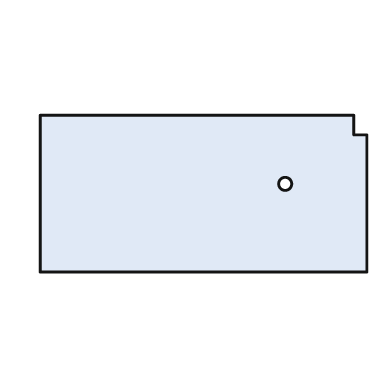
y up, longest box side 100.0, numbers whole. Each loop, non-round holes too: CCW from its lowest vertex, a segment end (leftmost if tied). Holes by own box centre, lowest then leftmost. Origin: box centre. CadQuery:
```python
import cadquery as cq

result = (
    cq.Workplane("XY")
    .moveTo(-50.0, -24.0)
    .lineTo(50.0, -24.0)
    .lineTo(50.0, 18.0)
    .lineTo(46.0, 18.0)
    .lineTo(46.0, 24.0)
    .lineTo(-50.0, 24.0)
    .close()
    .moveTo(25.0, 3.0)
    .circle(2.0)
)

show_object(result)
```